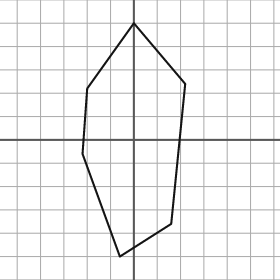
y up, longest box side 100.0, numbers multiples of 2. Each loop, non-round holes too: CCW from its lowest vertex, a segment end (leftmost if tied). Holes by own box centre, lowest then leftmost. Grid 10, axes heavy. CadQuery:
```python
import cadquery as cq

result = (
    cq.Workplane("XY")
    .moveTo(-6.0, -50.0)
    .lineTo(16.0, -36.0)
    .lineTo(22.0, 24.0)
    .lineTo(0.0, 50.0)
    .lineTo(-20.0, 22.0)
    .lineTo(-22.0, -6.0)
    .close()
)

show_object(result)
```